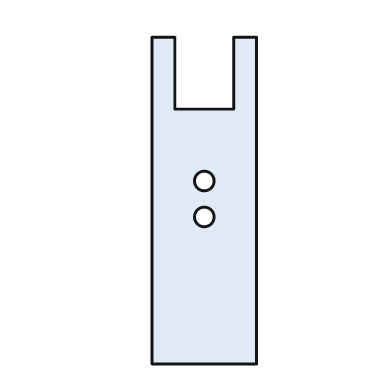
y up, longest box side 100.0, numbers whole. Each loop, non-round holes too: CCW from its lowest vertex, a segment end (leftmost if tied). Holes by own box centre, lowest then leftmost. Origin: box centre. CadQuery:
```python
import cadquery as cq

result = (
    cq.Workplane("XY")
    .moveTo(-16.0, -50.0)
    .lineTo(16.0, -50.0)
    .lineTo(16.0, 50.0)
    .lineTo(9.0, 50.0)
    .lineTo(9.0, 28.0)
    .lineTo(-9.0, 28.0)
    .lineTo(-9.0, 50.0)
    .lineTo(-16.0, 50.0)
    .close()
    .moveTo(0.0, -5.0)
    .circle(3.0)
    .moveTo(0.0, 6.0)
    .circle(3.0)
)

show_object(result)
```